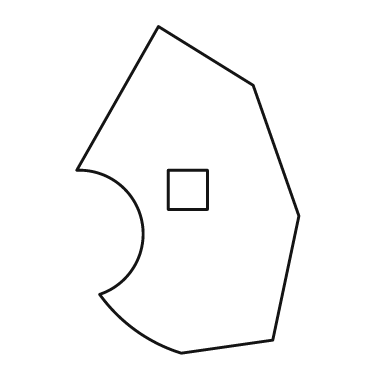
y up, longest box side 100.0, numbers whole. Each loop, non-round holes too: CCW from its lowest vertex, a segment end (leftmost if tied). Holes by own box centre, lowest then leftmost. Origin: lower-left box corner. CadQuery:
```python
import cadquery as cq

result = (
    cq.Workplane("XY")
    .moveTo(32.0, 0.0)
    .lineTo(60.0, 4.0)
    .lineTo(68.0, 42.0)
    .lineTo(54.0, 82.0)
    .lineTo(25.0, 100.0)
    .lineTo(0.0, 56.0)
    .threePointArc((20.0, 40.0), (7.0, 18.0))
    .threePointArc((18.0, 7.0), (32.0, 0.0))
    .close()
    .moveTo(28.0, 44.0)
    .lineTo(40.0, 44.0)
    .lineTo(40.0, 56.0)
    .lineTo(28.0, 56.0)
    .close()
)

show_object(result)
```